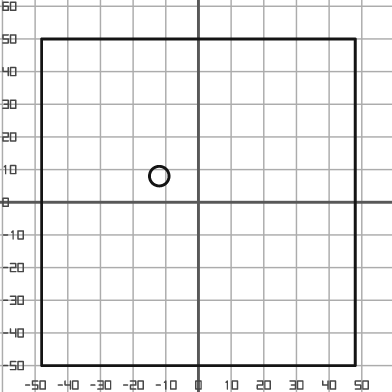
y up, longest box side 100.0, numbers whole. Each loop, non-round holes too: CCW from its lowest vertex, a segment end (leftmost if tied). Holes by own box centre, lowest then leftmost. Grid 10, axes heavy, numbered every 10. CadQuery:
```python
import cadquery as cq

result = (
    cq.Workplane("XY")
    .moveTo(-48.0, -50.0)
    .lineTo(48.0, -50.0)
    .lineTo(48.0, 50.0)
    .lineTo(-48.0, 50.0)
    .close()
    .moveTo(-12.0, 8.0)
    .circle(3.0)
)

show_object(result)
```